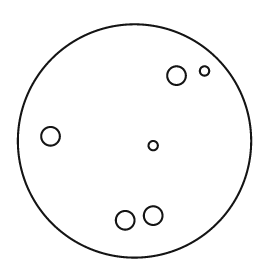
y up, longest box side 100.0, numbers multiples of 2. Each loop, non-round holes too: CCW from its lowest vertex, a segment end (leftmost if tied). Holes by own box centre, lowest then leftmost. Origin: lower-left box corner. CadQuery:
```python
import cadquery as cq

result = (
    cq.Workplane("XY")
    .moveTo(50.0, 50.0)
    .circle(50.0)
    .moveTo(46.0, 16.0)
    .circle(4.0)
    .moveTo(58.0, 18.0)
    .circle(4.0)
    .moveTo(58.0, 48.0)
    .circle(2.0)
    .moveTo(14.0, 52.0)
    .circle(4.0)
    .moveTo(68.0, 78.0)
    .circle(4.0)
    .moveTo(80.0, 80.0)
    .circle(2.0)
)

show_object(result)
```